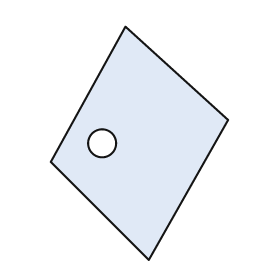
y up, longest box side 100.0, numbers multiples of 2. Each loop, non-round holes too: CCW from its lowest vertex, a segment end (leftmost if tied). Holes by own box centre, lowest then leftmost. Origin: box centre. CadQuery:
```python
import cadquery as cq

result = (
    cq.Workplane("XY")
    .moveTo(4.0, -50.0)
    .lineTo(38.0, 10.0)
    .lineTo(-6.0, 50.0)
    .lineTo(-38.0, -8.0)
    .close()
    .moveTo(-16.0, 0.0)
    .circle(6.0)
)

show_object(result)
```